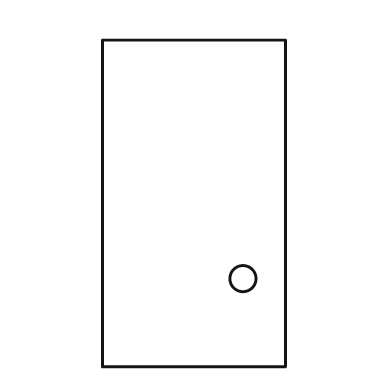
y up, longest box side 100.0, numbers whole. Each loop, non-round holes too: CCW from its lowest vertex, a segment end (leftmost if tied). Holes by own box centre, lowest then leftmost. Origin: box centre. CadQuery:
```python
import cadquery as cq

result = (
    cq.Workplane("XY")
    .moveTo(-28.0, -50.0)
    .lineTo(28.0, -50.0)
    .lineTo(28.0, 50.0)
    .lineTo(-28.0, 50.0)
    .close()
    .moveTo(15.0, -23.0)
    .circle(4.0)
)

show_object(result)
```